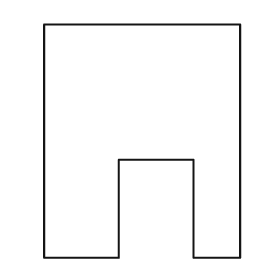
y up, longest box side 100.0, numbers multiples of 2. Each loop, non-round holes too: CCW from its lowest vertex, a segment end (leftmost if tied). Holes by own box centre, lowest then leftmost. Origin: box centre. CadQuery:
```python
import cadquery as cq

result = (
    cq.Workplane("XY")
    .moveTo(-42.0, -50.0)
    .lineTo(-10.0, -50.0)
    .lineTo(-10.0, -8.0)
    .lineTo(22.0, -8.0)
    .lineTo(22.0, -50.0)
    .lineTo(42.0, -50.0)
    .lineTo(42.0, 50.0)
    .lineTo(-42.0, 50.0)
    .close()
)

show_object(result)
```